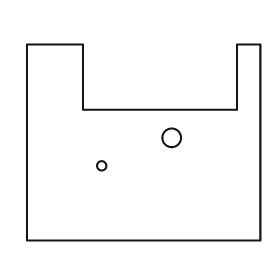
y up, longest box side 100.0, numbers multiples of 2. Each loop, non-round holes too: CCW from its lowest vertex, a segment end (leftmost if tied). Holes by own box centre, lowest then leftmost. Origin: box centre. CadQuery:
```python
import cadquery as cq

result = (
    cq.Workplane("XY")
    .moveTo(-50.0, -42.0)
    .lineTo(50.0, -42.0)
    .lineTo(50.0, 42.0)
    .lineTo(40.0, 42.0)
    .lineTo(40.0, 14.0)
    .lineTo(-26.0, 14.0)
    .lineTo(-26.0, 42.0)
    .lineTo(-50.0, 42.0)
    .close()
    .moveTo(-18.0, -10.0)
    .circle(2.0)
    .moveTo(12.0, 2.0)
    .circle(4.0)
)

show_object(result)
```